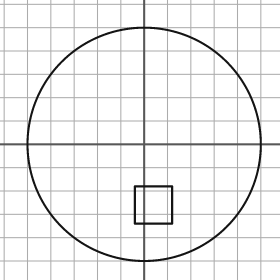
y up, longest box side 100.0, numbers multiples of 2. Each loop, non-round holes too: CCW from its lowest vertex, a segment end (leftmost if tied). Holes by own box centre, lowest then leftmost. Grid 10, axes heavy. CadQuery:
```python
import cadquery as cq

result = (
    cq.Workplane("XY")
    .moveTo(0.0, 0.0)
    .circle(50.0)
    .moveTo(-4.0, -34.0)
    .lineTo(12.0, -34.0)
    .lineTo(12.0, -18.0)
    .lineTo(-4.0, -18.0)
    .close()
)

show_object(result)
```